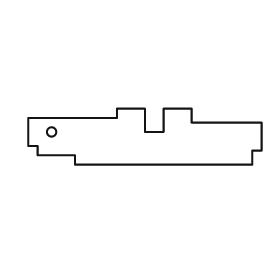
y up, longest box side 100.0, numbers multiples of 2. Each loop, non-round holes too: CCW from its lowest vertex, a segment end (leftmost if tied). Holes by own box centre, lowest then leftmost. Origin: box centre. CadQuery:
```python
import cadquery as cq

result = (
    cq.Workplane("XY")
    .moveTo(-30.0, -12.0)
    .lineTo(46.0, -12.0)
    .lineTo(46.0, -6.0)
    .lineTo(50.0, -6.0)
    .lineTo(50.0, 6.0)
    .lineTo(20.0, 6.0)
    .lineTo(20.0, 12.0)
    .lineTo(8.0, 12.0)
    .lineTo(8.0, 2.0)
    .lineTo(0.0, 2.0)
    .lineTo(0.0, 12.0)
    .lineTo(-12.0, 12.0)
    .lineTo(-12.0, 8.0)
    .lineTo(-50.0, 8.0)
    .lineTo(-50.0, -4.0)
    .lineTo(-46.0, -4.0)
    .lineTo(-46.0, -8.0)
    .lineTo(-30.0, -8.0)
    .close()
    .moveTo(-40.0, 2.0)
    .circle(2.0)
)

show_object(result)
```